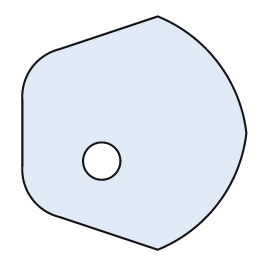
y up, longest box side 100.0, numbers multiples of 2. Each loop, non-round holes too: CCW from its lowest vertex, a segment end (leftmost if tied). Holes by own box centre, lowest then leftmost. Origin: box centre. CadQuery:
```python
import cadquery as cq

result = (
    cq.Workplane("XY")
    .moveTo(10.0, -50.0)
    .threePointArc((36.0, -30.0), (48.0, 0.0))
    .threePointArc((36.0, 30.0), (10.0, 50.0))
    .lineTo(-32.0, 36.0)
    .threePointArc((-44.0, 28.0), (-48.0, 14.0))
    .lineTo(-48.0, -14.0)
    .threePointArc((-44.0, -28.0), (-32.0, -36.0))
    .close()
    .moveTo(-14.0, -12.0)
    .circle(8.0)
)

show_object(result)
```